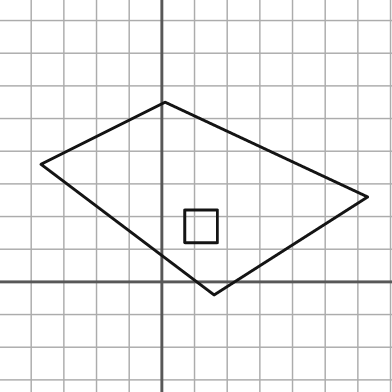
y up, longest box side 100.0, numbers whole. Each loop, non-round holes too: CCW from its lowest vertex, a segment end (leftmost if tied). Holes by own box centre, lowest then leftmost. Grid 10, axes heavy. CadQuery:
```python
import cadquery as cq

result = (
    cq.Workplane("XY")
    .moveTo(16.0, -4.0)
    .lineTo(63.0, 26.0)
    .lineTo(1.0, 55.0)
    .lineTo(-37.0, 36.0)
    .close()
    .moveTo(7.0, 12.0)
    .lineTo(17.0, 12.0)
    .lineTo(17.0, 22.0)
    .lineTo(7.0, 22.0)
    .close()
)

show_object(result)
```